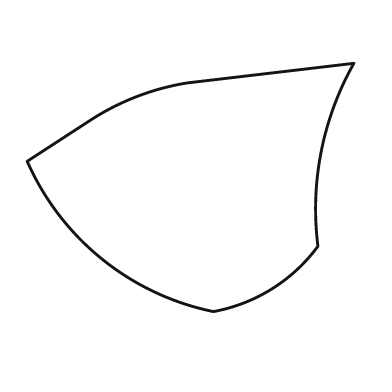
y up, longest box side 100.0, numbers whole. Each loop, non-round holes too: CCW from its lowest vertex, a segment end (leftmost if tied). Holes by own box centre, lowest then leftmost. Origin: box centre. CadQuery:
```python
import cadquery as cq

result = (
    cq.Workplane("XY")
    .moveTo(7.0, -38.0)
    .threePointArc((25.0, -31.0), (39.0, -18.0))
    .threePointArc((40.0, 11.0), (50.0, 38.0))
    .lineTo(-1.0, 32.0)
    .threePointArc((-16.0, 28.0), (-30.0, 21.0))
    .lineTo(-50.0, 8.0)
    .threePointArc((-27.0, -22.0), (7.0, -38.0))
    .close()
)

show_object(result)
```